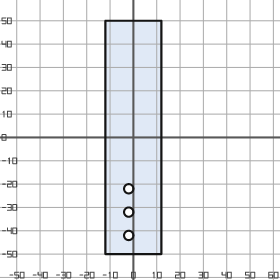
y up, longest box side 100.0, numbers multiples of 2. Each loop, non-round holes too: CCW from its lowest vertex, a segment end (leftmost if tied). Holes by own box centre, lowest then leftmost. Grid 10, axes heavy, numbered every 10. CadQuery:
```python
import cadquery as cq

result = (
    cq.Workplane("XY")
    .moveTo(-12.0, -50.0)
    .lineTo(12.0, -50.0)
    .lineTo(12.0, 50.0)
    .lineTo(-12.0, 50.0)
    .close()
    .moveTo(-2.0, -42.0)
    .circle(2.0)
    .moveTo(-2.0, -32.0)
    .circle(2.0)
    .moveTo(-2.0, -22.0)
    .circle(2.0)
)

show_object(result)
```